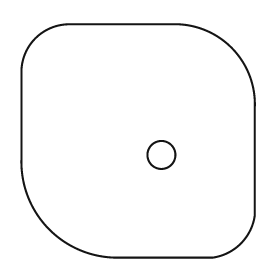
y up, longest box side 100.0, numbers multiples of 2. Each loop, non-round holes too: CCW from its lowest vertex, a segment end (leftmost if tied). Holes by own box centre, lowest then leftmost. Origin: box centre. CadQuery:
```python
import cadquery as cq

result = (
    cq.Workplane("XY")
    .moveTo(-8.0, -50.0)
    .lineTo(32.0, -50.0)
    .threePointArc((44.0, -44.0), (50.0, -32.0))
    .lineTo(50.0, 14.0)
    .threePointArc((40.0, 40.0), (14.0, 50.0))
    .lineTo(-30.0, 50.0)
    .threePointArc((-44.0, 44.0), (-50.0, 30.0))
    .lineTo(-50.0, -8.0)
    .threePointArc((-38.0, -38.0), (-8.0, -50.0))
    .close()
    .moveTo(10.0, -6.0)
    .circle(6.0)
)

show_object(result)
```